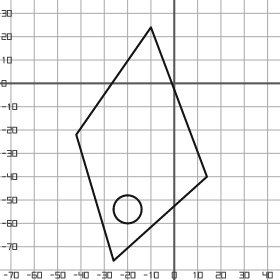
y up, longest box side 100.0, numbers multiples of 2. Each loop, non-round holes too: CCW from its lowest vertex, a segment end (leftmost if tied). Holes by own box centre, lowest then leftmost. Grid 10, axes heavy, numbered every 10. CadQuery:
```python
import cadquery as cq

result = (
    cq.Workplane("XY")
    .moveTo(-26.0, -76.0)
    .lineTo(14.0, -40.0)
    .lineTo(-10.0, 24.0)
    .lineTo(-42.0, -22.0)
    .close()
    .moveTo(-20.0, -54.0)
    .circle(6.0)
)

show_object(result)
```